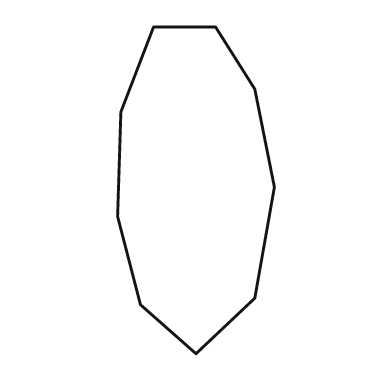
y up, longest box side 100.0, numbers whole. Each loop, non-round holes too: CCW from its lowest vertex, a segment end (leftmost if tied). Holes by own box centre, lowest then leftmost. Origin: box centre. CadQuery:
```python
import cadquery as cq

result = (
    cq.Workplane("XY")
    .moveTo(0.0, -50.0)
    .lineTo(18.0, -33.0)
    .lineTo(24.0, 1.0)
    .lineTo(18.0, 31.0)
    .lineTo(6.0, 50.0)
    .lineTo(-13.0, 50.0)
    .lineTo(-23.0, 24.0)
    .lineTo(-24.0, -8.0)
    .lineTo(-17.0, -35.0)
    .close()
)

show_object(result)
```